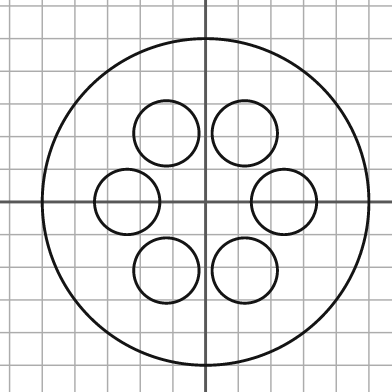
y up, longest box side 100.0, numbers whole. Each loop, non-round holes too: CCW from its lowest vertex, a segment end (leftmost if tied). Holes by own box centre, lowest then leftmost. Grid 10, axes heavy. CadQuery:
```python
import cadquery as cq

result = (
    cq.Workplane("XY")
    .moveTo(0.0, 0.0)
    .circle(50.0)
    .moveTo(-12.0, -21.0)
    .circle(10.0)
    .moveTo(12.0, -21.0)
    .circle(10.0)
    .moveTo(-24.0, 0.0)
    .circle(10.0)
    .moveTo(24.0, 0.0)
    .circle(10.0)
    .moveTo(-12.0, 21.0)
    .circle(10.0)
    .moveTo(12.0, 21.0)
    .circle(10.0)
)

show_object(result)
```